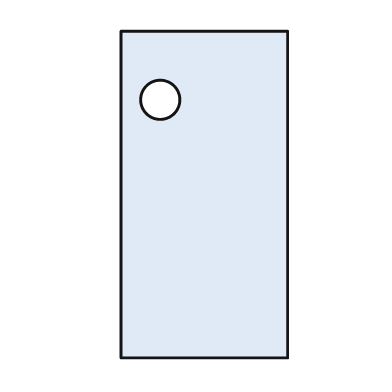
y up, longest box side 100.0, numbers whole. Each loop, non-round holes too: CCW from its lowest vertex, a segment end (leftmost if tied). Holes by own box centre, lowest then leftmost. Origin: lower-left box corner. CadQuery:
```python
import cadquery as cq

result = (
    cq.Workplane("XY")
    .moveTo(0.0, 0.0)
    .lineTo(51.0, 0.0)
    .lineTo(51.0, 100.0)
    .lineTo(0.0, 100.0)
    .close()
    .moveTo(12.0, 79.0)
    .circle(6.0)
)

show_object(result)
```